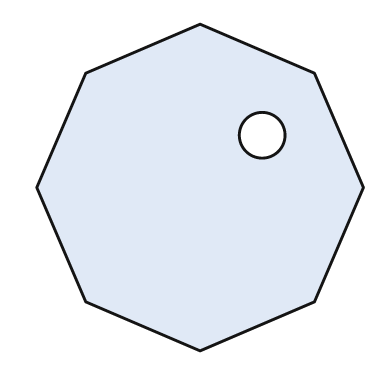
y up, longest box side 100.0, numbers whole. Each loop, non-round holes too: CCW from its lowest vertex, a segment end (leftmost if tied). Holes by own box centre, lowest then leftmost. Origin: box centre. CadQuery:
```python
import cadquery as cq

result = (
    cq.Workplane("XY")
    .moveTo(0.0, -50.0)
    .lineTo(35.0, -35.0)
    .lineTo(50.0, 0.0)
    .lineTo(35.0, 35.0)
    .lineTo(0.0, 50.0)
    .lineTo(-35.0, 35.0)
    .lineTo(-50.0, 0.0)
    .lineTo(-35.0, -35.0)
    .close()
    .moveTo(19.0, 16.0)
    .circle(7.0)
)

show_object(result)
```